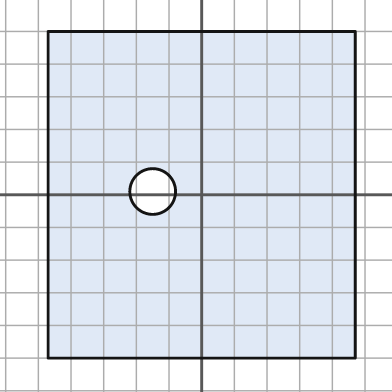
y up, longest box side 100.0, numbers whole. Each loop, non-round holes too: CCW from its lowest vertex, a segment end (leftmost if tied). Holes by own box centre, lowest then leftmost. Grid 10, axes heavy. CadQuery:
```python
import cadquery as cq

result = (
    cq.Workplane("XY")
    .moveTo(-47.0, -50.0)
    .lineTo(47.0, -50.0)
    .lineTo(47.0, 50.0)
    .lineTo(-47.0, 50.0)
    .close()
    .moveTo(-15.0, 1.0)
    .circle(7.0)
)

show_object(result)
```